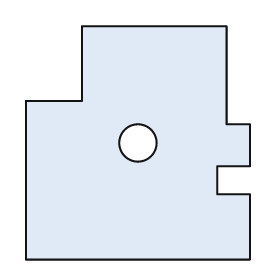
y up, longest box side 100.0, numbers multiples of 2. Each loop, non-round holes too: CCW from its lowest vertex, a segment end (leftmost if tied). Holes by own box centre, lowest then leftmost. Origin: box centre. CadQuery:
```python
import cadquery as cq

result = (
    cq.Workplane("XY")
    .moveTo(-48.0, -50.0)
    .lineTo(48.0, -50.0)
    .lineTo(48.0, -22.0)
    .lineTo(34.0, -22.0)
    .lineTo(34.0, -10.0)
    .lineTo(48.0, -10.0)
    .lineTo(48.0, 8.0)
    .lineTo(38.0, 8.0)
    .lineTo(38.0, 50.0)
    .lineTo(-24.0, 50.0)
    .lineTo(-24.0, 18.0)
    .lineTo(-48.0, 18.0)
    .close()
    .moveTo(0.0, 0.0)
    .circle(8.0)
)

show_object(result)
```